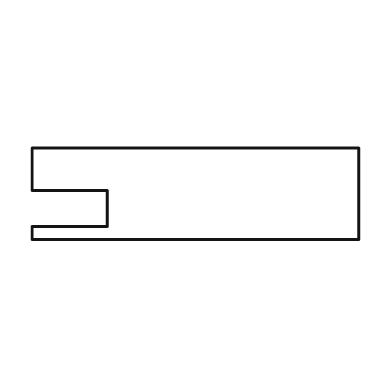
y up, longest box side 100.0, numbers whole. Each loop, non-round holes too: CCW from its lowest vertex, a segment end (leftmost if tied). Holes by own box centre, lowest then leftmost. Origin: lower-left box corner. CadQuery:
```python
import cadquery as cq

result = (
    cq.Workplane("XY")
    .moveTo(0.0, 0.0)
    .lineTo(100.0, 0.0)
    .lineTo(100.0, 28.0)
    .lineTo(0.0, 28.0)
    .lineTo(0.0, 15.0)
    .lineTo(23.0, 15.0)
    .lineTo(23.0, 4.0)
    .lineTo(0.0, 4.0)
    .close()
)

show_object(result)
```